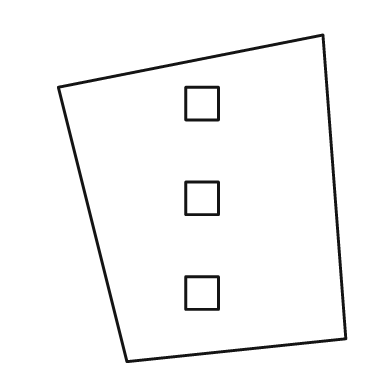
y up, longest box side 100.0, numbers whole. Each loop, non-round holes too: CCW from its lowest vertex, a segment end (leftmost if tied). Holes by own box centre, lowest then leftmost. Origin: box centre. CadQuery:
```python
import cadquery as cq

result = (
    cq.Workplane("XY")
    .moveTo(-23.0, -50.0)
    .lineTo(44.0, -43.0)
    .lineTo(37.0, 50.0)
    .lineTo(-44.0, 34.0)
    .close()
    .moveTo(-5.0, -34.0)
    .lineTo(5.0, -34.0)
    .lineTo(5.0, -24.0)
    .lineTo(-5.0, -24.0)
    .close()
    .moveTo(-5.0, -5.0)
    .lineTo(5.0, -5.0)
    .lineTo(5.0, 5.0)
    .lineTo(-5.0, 5.0)
    .close()
    .moveTo(-5.0, 24.0)
    .lineTo(5.0, 24.0)
    .lineTo(5.0, 34.0)
    .lineTo(-5.0, 34.0)
    .close()
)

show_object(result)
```